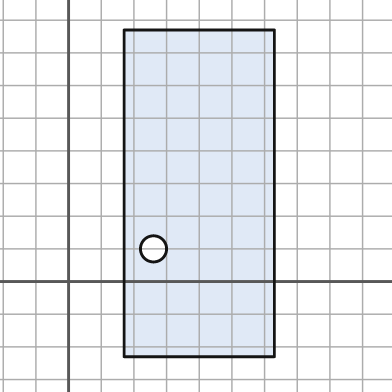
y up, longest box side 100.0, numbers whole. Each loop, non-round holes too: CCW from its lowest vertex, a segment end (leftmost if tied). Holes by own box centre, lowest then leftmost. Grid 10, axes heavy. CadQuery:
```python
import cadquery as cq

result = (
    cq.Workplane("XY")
    .moveTo(17.0, -23.0)
    .lineTo(63.0, -23.0)
    .lineTo(63.0, 77.0)
    .lineTo(17.0, 77.0)
    .close()
    .moveTo(26.0, 10.0)
    .circle(4.0)
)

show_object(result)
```